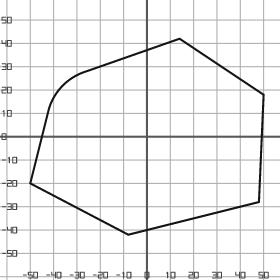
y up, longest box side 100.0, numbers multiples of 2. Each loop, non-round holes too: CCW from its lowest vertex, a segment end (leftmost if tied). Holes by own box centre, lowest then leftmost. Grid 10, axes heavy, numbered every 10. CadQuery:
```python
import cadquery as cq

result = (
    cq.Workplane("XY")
    .moveTo(-8.0, -42.0)
    .lineTo(48.0, -28.0)
    .lineTo(50.0, 18.0)
    .lineTo(14.0, 42.0)
    .lineTo(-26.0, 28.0)
    .threePointArc((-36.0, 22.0), (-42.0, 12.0))
    .lineTo(-50.0, -20.0)
    .close()
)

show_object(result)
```